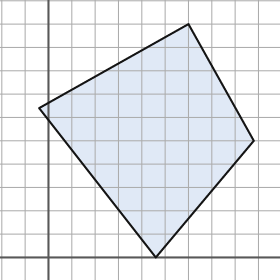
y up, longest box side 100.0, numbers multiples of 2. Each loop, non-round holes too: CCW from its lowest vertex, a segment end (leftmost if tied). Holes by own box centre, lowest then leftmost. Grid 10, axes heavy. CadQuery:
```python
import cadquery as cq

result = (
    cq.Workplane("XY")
    .moveTo(46.0, 0.0)
    .lineTo(88.0, 50.0)
    .lineTo(60.0, 100.0)
    .lineTo(-4.0, 64.0)
    .close()
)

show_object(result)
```